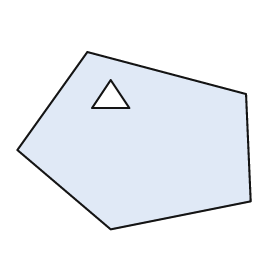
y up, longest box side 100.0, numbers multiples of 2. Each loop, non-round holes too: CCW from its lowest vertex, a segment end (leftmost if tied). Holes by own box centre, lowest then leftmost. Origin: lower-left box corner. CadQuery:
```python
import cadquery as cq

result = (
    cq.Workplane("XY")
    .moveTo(40.0, 0.0)
    .lineTo(100.0, 12.0)
    .lineTo(98.0, 58.0)
    .lineTo(30.0, 76.0)
    .lineTo(0.0, 34.0)
    .close()
    .moveTo(32.0, 52.0)
    .lineTo(48.0, 52.0)
    .lineTo(40.0, 64.0)
    .close()
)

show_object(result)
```